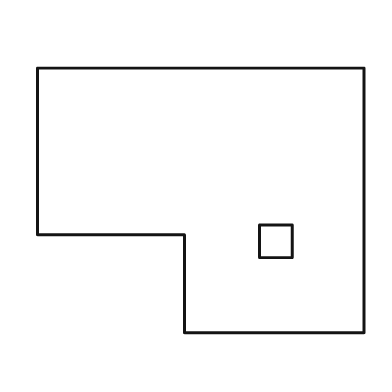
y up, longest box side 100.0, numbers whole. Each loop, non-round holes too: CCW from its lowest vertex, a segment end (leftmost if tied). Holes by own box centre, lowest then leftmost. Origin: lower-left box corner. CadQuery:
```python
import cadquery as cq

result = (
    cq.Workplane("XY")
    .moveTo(45.0, 0.0)
    .lineTo(100.0, 0.0)
    .lineTo(100.0, 81.0)
    .lineTo(0.0, 81.0)
    .lineTo(0.0, 30.0)
    .lineTo(45.0, 30.0)
    .close()
    .moveTo(68.0, 23.0)
    .lineTo(78.0, 23.0)
    .lineTo(78.0, 33.0)
    .lineTo(68.0, 33.0)
    .close()
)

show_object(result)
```